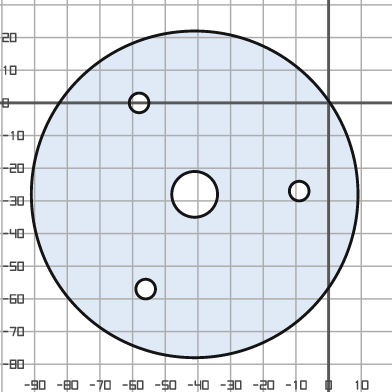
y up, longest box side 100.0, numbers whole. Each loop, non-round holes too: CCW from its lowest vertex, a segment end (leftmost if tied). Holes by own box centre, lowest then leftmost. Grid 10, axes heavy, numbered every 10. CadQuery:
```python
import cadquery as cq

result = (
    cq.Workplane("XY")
    .moveTo(-41.0, -28.0)
    .circle(50.0)
    .moveTo(-56.0, -57.0)
    .circle(3.0)
    .moveTo(-41.0, -28.0)
    .circle(7.0)
    .moveTo(-9.0, -27.0)
    .circle(3.0)
    .moveTo(-58.0, 0.0)
    .circle(3.0)
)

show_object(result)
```